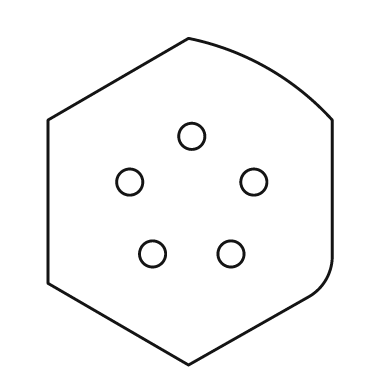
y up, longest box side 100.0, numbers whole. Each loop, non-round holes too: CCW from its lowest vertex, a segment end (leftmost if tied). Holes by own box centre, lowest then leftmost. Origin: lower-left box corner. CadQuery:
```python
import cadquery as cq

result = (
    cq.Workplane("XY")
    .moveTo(43.0, 0.0)
    .lineTo(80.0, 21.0)
    .threePointArc((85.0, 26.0), (87.0, 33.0))
    .lineTo(87.0, 75.0)
    .threePointArc((67.0, 91.0), (43.0, 100.0))
    .lineTo(0.0, 75.0)
    .lineTo(0.0, 25.0)
    .close()
    .moveTo(32.0, 34.0)
    .circle(4.0)
    .moveTo(56.0, 34.0)
    .circle(4.0)
    .moveTo(25.0, 56.0)
    .circle(4.0)
    .moveTo(63.0, 56.0)
    .circle(4.0)
    .moveTo(44.0, 70.0)
    .circle(4.0)
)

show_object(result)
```